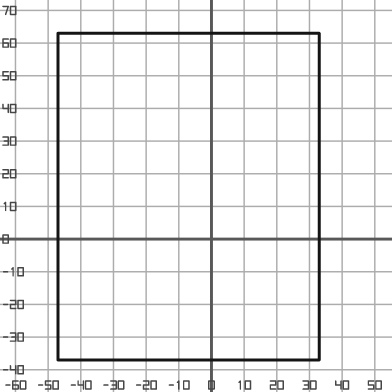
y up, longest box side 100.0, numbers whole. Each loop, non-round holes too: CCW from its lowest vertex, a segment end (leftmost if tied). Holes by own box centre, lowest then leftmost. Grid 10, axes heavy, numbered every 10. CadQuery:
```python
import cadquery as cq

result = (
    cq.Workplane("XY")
    .moveTo(-47.0, -37.0)
    .lineTo(33.0, -37.0)
    .lineTo(33.0, 63.0)
    .lineTo(-47.0, 63.0)
    .close()
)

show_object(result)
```